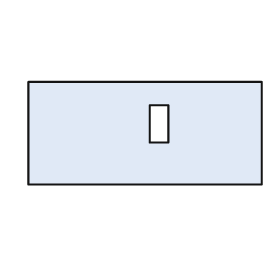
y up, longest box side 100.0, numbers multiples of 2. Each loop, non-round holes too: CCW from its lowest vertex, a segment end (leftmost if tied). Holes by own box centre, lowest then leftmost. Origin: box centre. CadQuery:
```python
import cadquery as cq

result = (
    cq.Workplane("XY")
    .moveTo(-50.0, -22.0)
    .lineTo(50.0, -22.0)
    .lineTo(50.0, 22.0)
    .lineTo(-50.0, 22.0)
    .close()
    .moveTo(2.0, -4.0)
    .lineTo(10.0, -4.0)
    .lineTo(10.0, 12.0)
    .lineTo(2.0, 12.0)
    .close()
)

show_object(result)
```